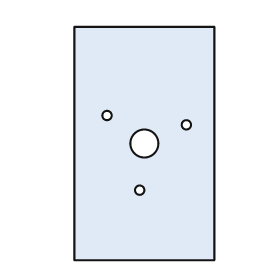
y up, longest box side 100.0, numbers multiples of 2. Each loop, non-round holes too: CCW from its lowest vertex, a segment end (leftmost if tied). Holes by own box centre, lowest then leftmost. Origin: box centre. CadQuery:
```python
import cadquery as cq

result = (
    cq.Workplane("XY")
    .moveTo(-30.0, -50.0)
    .lineTo(30.0, -50.0)
    .lineTo(30.0, 50.0)
    .lineTo(-30.0, 50.0)
    .close()
    .moveTo(-2.0, -20.0)
    .circle(2.0)
    .moveTo(0.0, 0.0)
    .circle(6.0)
    .moveTo(18.0, 8.0)
    .circle(2.0)
    .moveTo(-16.0, 12.0)
    .circle(2.0)
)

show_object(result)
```